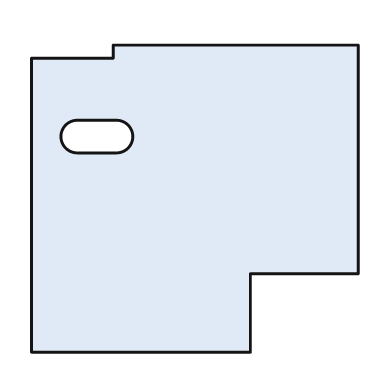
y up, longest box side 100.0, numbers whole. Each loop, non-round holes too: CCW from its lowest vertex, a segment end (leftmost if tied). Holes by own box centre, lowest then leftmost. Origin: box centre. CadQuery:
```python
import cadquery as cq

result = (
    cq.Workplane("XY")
    .moveTo(-50.0, -47.0)
    .lineTo(17.0, -47.0)
    .lineTo(17.0, -23.0)
    .lineTo(50.0, -23.0)
    .lineTo(50.0, 47.0)
    .lineTo(-25.0, 47.0)
    .lineTo(-25.0, 43.0)
    .lineTo(-50.0, 43.0)
    .close()
    .moveTo(-36.0, 14.0)
    .lineTo(-24.0, 14.0)
    .threePointArc((-19.0, 19.0), (-24.0, 24.0))
    .lineTo(-36.0, 24.0)
    .threePointArc((-41.0, 19.0), (-36.0, 14.0))
    .close()
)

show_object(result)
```